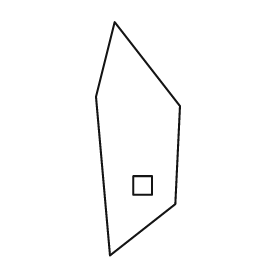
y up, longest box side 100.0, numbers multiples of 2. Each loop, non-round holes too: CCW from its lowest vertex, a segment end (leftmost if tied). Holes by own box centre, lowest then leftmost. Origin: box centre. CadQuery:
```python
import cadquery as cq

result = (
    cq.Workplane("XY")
    .moveTo(-12.0, -50.0)
    .lineTo(16.0, -28.0)
    .lineTo(18.0, 14.0)
    .lineTo(-10.0, 50.0)
    .lineTo(-18.0, 18.0)
    .close()
    .moveTo(-2.0, -24.0)
    .lineTo(6.0, -24.0)
    .lineTo(6.0, -16.0)
    .lineTo(-2.0, -16.0)
    .close()
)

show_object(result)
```